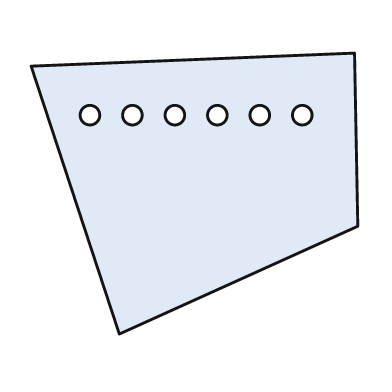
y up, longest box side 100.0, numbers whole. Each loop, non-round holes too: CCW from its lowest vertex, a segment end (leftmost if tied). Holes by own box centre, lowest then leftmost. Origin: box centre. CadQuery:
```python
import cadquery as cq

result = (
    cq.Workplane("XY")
    .moveTo(-23.0, -43.0)
    .lineTo(50.0, -10.0)
    .lineTo(49.0, 43.0)
    .lineTo(-50.0, 39.0)
    .close()
    .moveTo(-32.0, 24.0)
    .circle(3.0)
    .moveTo(-19.0, 24.0)
    .circle(3.0)
    .moveTo(-6.0, 24.0)
    .circle(3.0)
    .moveTo(7.0, 24.0)
    .circle(3.0)
    .moveTo(20.0, 24.0)
    .circle(3.0)
    .moveTo(33.0, 24.0)
    .circle(3.0)
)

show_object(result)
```